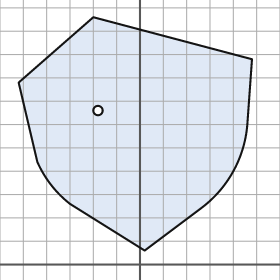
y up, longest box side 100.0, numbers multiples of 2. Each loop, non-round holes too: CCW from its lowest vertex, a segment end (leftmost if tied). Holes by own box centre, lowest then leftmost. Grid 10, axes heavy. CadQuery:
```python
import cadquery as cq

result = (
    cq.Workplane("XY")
    .moveTo(2.0, 6.0)
    .lineTo(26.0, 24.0)
    .threePointArc((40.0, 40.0), (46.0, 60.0))
    .lineTo(48.0, 88.0)
    .lineTo(-20.0, 106.0)
    .lineTo(-52.0, 78.0)
    .lineTo(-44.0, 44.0)
    .threePointArc((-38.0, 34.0), (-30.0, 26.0))
    .close()
    .moveTo(-18.0, 66.0)
    .circle(2.0)
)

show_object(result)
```